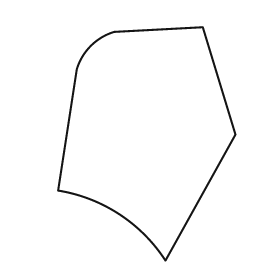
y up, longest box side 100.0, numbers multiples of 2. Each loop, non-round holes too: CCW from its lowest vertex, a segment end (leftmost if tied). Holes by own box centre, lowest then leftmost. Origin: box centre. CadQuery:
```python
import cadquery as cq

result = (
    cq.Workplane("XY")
    .moveTo(8.0, -50.0)
    .lineTo(38.0, 4.0)
    .lineTo(24.0, 50.0)
    .lineTo(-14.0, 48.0)
    .threePointArc((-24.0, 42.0), (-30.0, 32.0))
    .lineTo(-38.0, -20.0)
    .threePointArc((-12.0, -30.0), (8.0, -50.0))
    .close()
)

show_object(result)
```